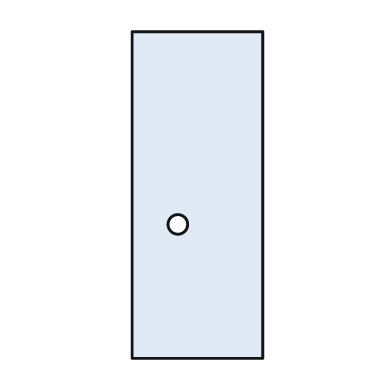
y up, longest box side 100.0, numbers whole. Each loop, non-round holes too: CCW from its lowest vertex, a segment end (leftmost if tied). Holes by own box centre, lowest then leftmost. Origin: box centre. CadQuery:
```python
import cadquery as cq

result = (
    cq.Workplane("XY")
    .moveTo(-20.0, -50.0)
    .lineTo(20.0, -50.0)
    .lineTo(20.0, 50.0)
    .lineTo(-20.0, 50.0)
    .close()
    .moveTo(-6.0, -9.0)
    .circle(3.0)
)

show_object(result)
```